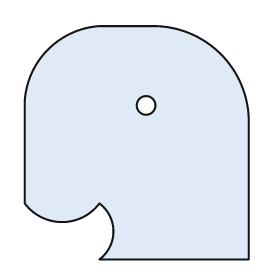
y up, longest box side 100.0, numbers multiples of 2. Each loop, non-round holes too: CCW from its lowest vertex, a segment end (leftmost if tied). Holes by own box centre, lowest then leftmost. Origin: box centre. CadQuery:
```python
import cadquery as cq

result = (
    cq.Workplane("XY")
    .moveTo(-16.0, -50.0)
    .lineTo(48.0, -50.0)
    .lineTo(48.0, 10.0)
    .threePointArc((36.0, 38.0), (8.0, 50.0))
    .lineTo(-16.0, 50.0)
    .threePointArc((-38.0, 40.0), (-48.0, 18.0))
    .lineTo(-48.0, -26.0)
    .threePointArc((-32.0, -34.0), (-16.0, -26.0))
    .threePointArc((-10.0, -38.0), (-16.0, -50.0))
    .close()
    .moveTo(4.0, 16.0)
    .circle(4.0)
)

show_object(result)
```